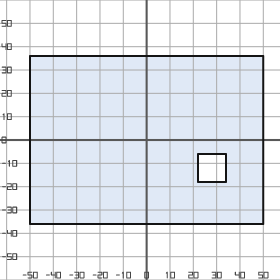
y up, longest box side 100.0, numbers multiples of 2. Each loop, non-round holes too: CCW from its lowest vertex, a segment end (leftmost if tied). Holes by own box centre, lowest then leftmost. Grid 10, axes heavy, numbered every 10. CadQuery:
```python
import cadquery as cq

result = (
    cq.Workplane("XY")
    .moveTo(-50.0, -36.0)
    .lineTo(50.0, -36.0)
    .lineTo(50.0, 36.0)
    .lineTo(-50.0, 36.0)
    .close()
    .moveTo(22.0, -18.0)
    .lineTo(34.0, -18.0)
    .lineTo(34.0, -6.0)
    .lineTo(22.0, -6.0)
    .close()
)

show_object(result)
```